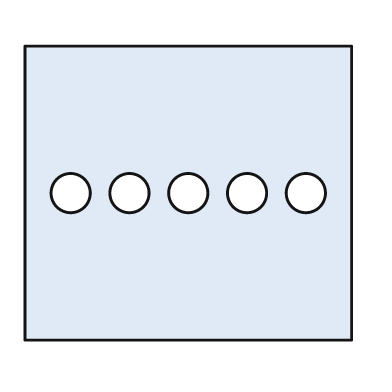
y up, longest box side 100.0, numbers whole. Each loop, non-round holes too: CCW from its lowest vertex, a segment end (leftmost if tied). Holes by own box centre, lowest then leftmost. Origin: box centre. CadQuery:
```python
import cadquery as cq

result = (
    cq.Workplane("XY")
    .moveTo(-50.0, -45.0)
    .lineTo(50.0, -45.0)
    .lineTo(50.0, 45.0)
    .lineTo(-50.0, 45.0)
    .close()
    .moveTo(-36.0, 0.0)
    .circle(6.0)
    .moveTo(-18.0, 0.0)
    .circle(6.0)
    .moveTo(0.0, 0.0)
    .circle(6.0)
    .moveTo(18.0, 0.0)
    .circle(6.0)
    .moveTo(36.0, 0.0)
    .circle(6.0)
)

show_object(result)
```